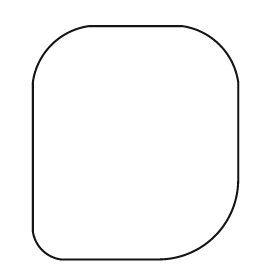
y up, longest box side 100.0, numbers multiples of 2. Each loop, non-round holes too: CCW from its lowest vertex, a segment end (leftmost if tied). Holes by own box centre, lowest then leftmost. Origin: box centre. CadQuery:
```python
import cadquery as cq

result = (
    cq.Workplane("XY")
    .moveTo(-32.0, -50.0)
    .lineTo(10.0, -50.0)
    .threePointArc((34.0, -40.0), (44.0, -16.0))
    .lineTo(44.0, 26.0)
    .threePointArc((36.0, 42.0), (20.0, 50.0))
    .lineTo(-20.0, 50.0)
    .threePointArc((-36.0, 42.0), (-44.0, 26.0))
    .lineTo(-44.0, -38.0)
    .threePointArc((-40.0, -46.0), (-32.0, -50.0))
    .close()
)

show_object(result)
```